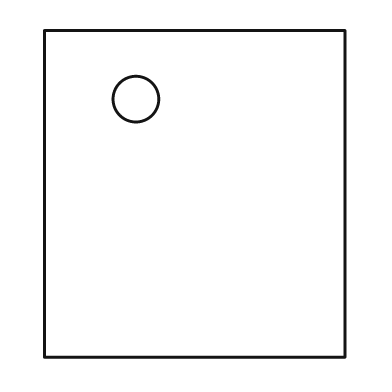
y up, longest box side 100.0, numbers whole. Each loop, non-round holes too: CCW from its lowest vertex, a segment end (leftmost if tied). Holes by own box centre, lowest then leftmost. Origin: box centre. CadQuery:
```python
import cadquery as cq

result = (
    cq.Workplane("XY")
    .moveTo(-46.0, -50.0)
    .lineTo(46.0, -50.0)
    .lineTo(46.0, 50.0)
    .lineTo(-46.0, 50.0)
    .close()
    .moveTo(-18.0, 29.0)
    .circle(7.0)
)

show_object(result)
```